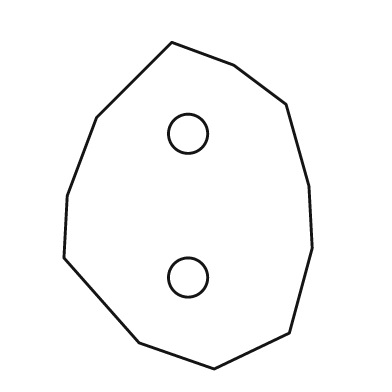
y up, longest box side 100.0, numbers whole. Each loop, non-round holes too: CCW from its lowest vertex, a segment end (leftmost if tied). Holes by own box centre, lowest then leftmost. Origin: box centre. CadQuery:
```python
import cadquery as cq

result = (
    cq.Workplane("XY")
    .moveTo(8.0, -50.0)
    .lineTo(31.0, -39.0)
    .lineTo(38.0, -13.0)
    .lineTo(37.0, 6.0)
    .lineTo(30.0, 31.0)
    .lineTo(14.0, 43.0)
    .lineTo(-5.0, 50.0)
    .lineTo(-28.0, 27.0)
    .lineTo(-37.0, 3.0)
    .lineTo(-38.0, -16.0)
    .lineTo(-15.0, -42.0)
    .close()
    .moveTo(0.0, -22.0)
    .circle(6.0)
    .moveTo(0.0, 22.0)
    .circle(6.0)
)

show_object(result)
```